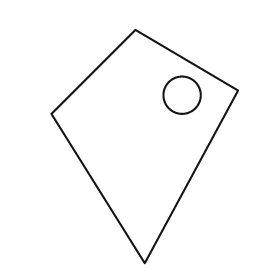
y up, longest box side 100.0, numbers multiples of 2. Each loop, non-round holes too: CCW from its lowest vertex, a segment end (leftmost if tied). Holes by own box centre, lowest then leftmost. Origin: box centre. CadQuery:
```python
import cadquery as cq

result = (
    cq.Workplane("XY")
    .moveTo(0.0, -50.0)
    .lineTo(40.0, 24.0)
    .lineTo(-4.0, 50.0)
    .lineTo(-40.0, 14.0)
    .close()
    .moveTo(16.0, 22.0)
    .circle(8.0)
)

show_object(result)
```